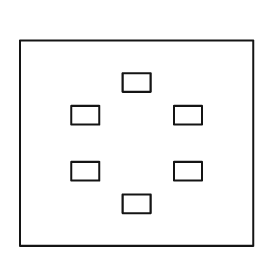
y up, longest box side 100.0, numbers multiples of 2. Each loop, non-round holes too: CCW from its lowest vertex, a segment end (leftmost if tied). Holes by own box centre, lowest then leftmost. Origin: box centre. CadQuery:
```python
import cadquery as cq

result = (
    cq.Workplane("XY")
    .moveTo(-50.0, -44.0)
    .lineTo(50.0, -44.0)
    .lineTo(50.0, 44.0)
    .lineTo(-50.0, 44.0)
    .close()
    .moveTo(-6.0, -30.0)
    .lineTo(6.0, -30.0)
    .lineTo(6.0, -22.0)
    .lineTo(-6.0, -22.0)
    .close()
    .moveTo(-28.0, -16.0)
    .lineTo(-16.0, -16.0)
    .lineTo(-16.0, -8.0)
    .lineTo(-28.0, -8.0)
    .close()
    .moveTo(16.0, -16.0)
    .lineTo(28.0, -16.0)
    .lineTo(28.0, -8.0)
    .lineTo(16.0, -8.0)
    .close()
    .moveTo(-28.0, 8.0)
    .lineTo(-16.0, 8.0)
    .lineTo(-16.0, 16.0)
    .lineTo(-28.0, 16.0)
    .close()
    .moveTo(16.0, 8.0)
    .lineTo(28.0, 8.0)
    .lineTo(28.0, 16.0)
    .lineTo(16.0, 16.0)
    .close()
    .moveTo(-6.0, 22.0)
    .lineTo(6.0, 22.0)
    .lineTo(6.0, 30.0)
    .lineTo(-6.0, 30.0)
    .close()
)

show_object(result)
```